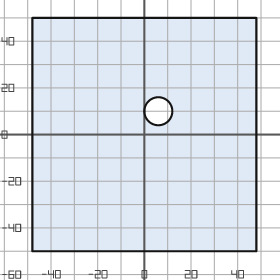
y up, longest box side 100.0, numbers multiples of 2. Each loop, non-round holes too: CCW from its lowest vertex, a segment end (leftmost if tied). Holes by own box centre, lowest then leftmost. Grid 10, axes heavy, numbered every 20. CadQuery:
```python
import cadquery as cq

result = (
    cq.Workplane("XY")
    .moveTo(-48.0, -50.0)
    .lineTo(48.0, -50.0)
    .lineTo(48.0, 50.0)
    .lineTo(-48.0, 50.0)
    .close()
    .moveTo(6.0, 10.0)
    .circle(6.0)
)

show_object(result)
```